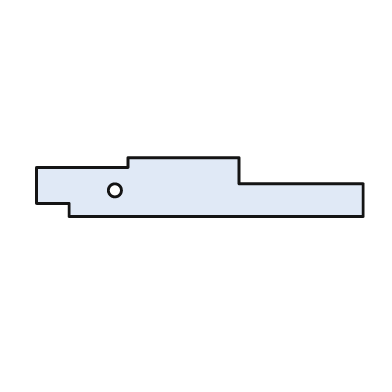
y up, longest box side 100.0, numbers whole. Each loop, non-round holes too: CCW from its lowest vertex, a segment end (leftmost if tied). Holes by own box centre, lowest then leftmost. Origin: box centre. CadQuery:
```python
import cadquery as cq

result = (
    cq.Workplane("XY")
    .moveTo(-40.0, -9.0)
    .lineTo(50.0, -9.0)
    .lineTo(50.0, 1.0)
    .lineTo(12.0, 1.0)
    .lineTo(12.0, 9.0)
    .lineTo(-22.0, 9.0)
    .lineTo(-22.0, 6.0)
    .lineTo(-50.0, 6.0)
    .lineTo(-50.0, -5.0)
    .lineTo(-40.0, -5.0)
    .close()
    .moveTo(-26.0, -1.0)
    .circle(2.0)
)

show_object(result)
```